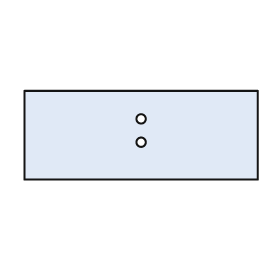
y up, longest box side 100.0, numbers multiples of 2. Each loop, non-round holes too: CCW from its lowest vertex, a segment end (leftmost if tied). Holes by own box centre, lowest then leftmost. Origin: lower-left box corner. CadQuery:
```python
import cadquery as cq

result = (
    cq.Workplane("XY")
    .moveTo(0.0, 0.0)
    .lineTo(100.0, 0.0)
    .lineTo(100.0, 38.0)
    .lineTo(0.0, 38.0)
    .close()
    .moveTo(50.0, 16.0)
    .circle(2.0)
    .moveTo(50.0, 26.0)
    .circle(2.0)
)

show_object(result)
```